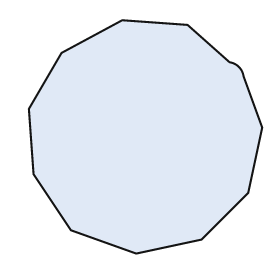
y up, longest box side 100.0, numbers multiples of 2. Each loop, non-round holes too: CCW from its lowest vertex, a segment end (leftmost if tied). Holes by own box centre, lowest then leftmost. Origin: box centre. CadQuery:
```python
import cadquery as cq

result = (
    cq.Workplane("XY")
    .moveTo(-4.0, -50.0)
    .lineTo(24.0, -44.0)
    .lineTo(44.0, -24.0)
    .lineTo(50.0, 4.0)
    .lineTo(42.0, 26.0)
    .threePointArc((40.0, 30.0), (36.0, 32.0))
    .lineTo(18.0, 48.0)
    .lineTo(-10.0, 50.0)
    .lineTo(-36.0, 36.0)
    .lineTo(-50.0, 12.0)
    .lineTo(-48.0, -16.0)
    .lineTo(-32.0, -40.0)
    .close()
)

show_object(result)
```